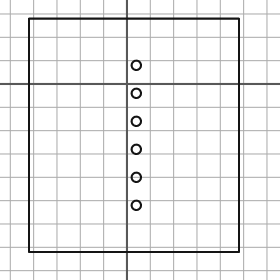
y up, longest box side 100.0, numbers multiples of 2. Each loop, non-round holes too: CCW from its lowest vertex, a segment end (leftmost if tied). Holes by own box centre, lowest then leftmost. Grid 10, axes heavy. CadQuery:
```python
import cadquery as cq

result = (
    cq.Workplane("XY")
    .moveTo(-42.0, -72.0)
    .lineTo(48.0, -72.0)
    .lineTo(48.0, 28.0)
    .lineTo(-42.0, 28.0)
    .close()
    .moveTo(4.0, -52.0)
    .circle(2.0)
    .moveTo(4.0, -40.0)
    .circle(2.0)
    .moveTo(4.0, -28.0)
    .circle(2.0)
    .moveTo(4.0, -16.0)
    .circle(2.0)
    .moveTo(4.0, -4.0)
    .circle(2.0)
    .moveTo(4.0, 8.0)
    .circle(2.0)
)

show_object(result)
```